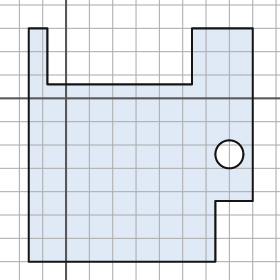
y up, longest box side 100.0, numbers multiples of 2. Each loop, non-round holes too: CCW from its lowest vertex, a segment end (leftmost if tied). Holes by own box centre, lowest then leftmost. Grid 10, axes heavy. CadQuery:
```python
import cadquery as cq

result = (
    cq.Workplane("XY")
    .moveTo(-16.0, -70.0)
    .lineTo(64.0, -70.0)
    .lineTo(64.0, -44.0)
    .lineTo(80.0, -44.0)
    .lineTo(80.0, 30.0)
    .lineTo(54.0, 30.0)
    .lineTo(54.0, 6.0)
    .lineTo(-8.0, 6.0)
    .lineTo(-8.0, 30.0)
    .lineTo(-16.0, 30.0)
    .close()
    .moveTo(70.0, -24.0)
    .circle(6.0)
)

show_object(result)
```